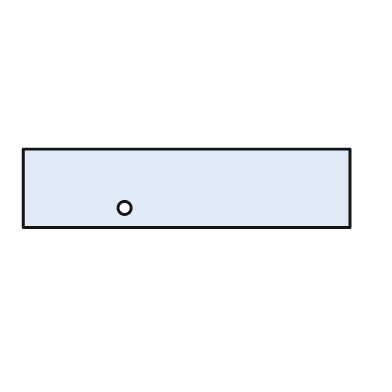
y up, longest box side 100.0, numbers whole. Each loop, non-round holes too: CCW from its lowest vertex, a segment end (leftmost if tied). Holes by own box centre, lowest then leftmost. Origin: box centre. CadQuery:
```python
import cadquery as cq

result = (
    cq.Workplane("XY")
    .moveTo(-50.0, -12.0)
    .lineTo(50.0, -12.0)
    .lineTo(50.0, 12.0)
    .lineTo(-50.0, 12.0)
    .close()
    .moveTo(-19.0, -6.0)
    .circle(2.0)
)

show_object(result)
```